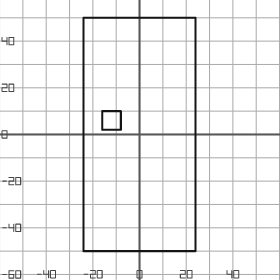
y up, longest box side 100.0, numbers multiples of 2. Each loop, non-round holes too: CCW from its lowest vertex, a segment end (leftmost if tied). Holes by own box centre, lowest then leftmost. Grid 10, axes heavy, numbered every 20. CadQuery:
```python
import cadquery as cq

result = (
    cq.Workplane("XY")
    .moveTo(-24.0, -50.0)
    .lineTo(24.0, -50.0)
    .lineTo(24.0, 50.0)
    .lineTo(-24.0, 50.0)
    .close()
    .moveTo(-16.0, 2.0)
    .lineTo(-8.0, 2.0)
    .lineTo(-8.0, 10.0)
    .lineTo(-16.0, 10.0)
    .close()
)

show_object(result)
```